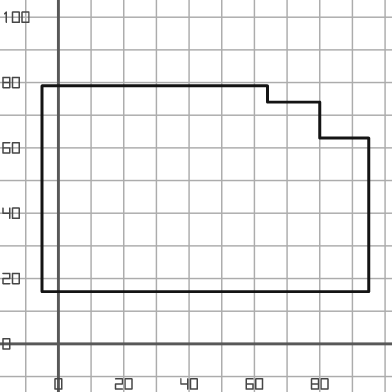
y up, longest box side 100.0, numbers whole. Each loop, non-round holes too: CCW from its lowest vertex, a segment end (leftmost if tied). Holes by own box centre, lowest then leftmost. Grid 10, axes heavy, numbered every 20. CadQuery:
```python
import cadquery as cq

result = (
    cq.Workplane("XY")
    .moveTo(-5.0, 16.0)
    .lineTo(95.0, 16.0)
    .lineTo(95.0, 63.0)
    .lineTo(80.0, 63.0)
    .lineTo(80.0, 74.0)
    .lineTo(64.0, 74.0)
    .lineTo(64.0, 79.0)
    .lineTo(-5.0, 79.0)
    .close()
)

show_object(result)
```